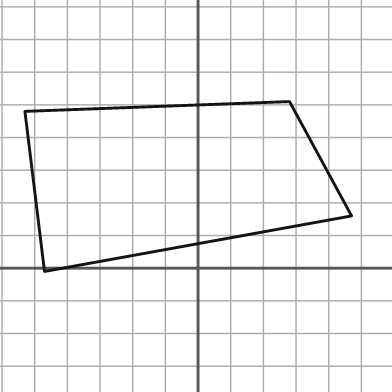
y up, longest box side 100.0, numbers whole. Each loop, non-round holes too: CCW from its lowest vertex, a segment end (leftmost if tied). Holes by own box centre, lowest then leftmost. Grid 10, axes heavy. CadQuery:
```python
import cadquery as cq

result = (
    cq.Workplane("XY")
    .moveTo(-47.0, -1.0)
    .lineTo(47.0, 16.0)
    .lineTo(28.0, 51.0)
    .lineTo(-53.0, 48.0)
    .close()
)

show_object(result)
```